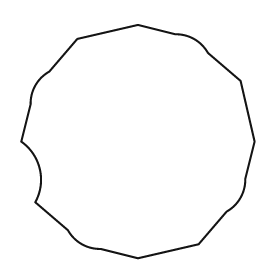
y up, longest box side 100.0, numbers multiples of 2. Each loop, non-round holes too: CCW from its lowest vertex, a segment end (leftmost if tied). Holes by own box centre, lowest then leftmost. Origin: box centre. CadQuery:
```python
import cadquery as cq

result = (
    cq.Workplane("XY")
    .moveTo(0.0, -50.0)
    .lineTo(26.0, -44.0)
    .lineTo(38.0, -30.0)
    .threePointArc((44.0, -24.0), (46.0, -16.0))
    .lineTo(50.0, 0.0)
    .lineTo(44.0, 26.0)
    .lineTo(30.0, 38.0)
    .threePointArc((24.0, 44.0), (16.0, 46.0))
    .lineTo(0.0, 50.0)
    .lineTo(-26.0, 44.0)
    .lineTo(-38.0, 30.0)
    .threePointArc((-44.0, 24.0), (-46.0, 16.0))
    .lineTo(-50.0, 0.0)
    .threePointArc((-42.0, -12.0), (-44.0, -26.0))
    .lineTo(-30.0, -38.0)
    .threePointArc((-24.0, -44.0), (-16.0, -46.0))
    .close()
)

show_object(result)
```